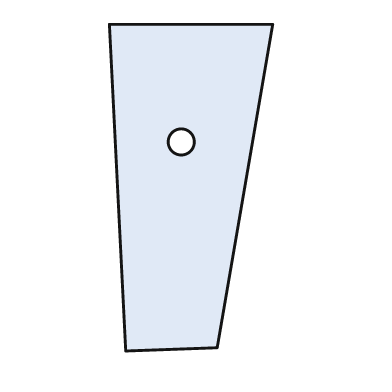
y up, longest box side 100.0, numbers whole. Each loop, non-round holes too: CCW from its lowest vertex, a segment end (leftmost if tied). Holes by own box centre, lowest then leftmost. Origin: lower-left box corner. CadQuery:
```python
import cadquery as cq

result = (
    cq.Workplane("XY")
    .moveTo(5.0, 0.0)
    .lineTo(33.0, 1.0)
    .lineTo(50.0, 100.0)
    .lineTo(0.0, 100.0)
    .close()
    .moveTo(22.0, 64.0)
    .circle(4.0)
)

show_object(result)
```